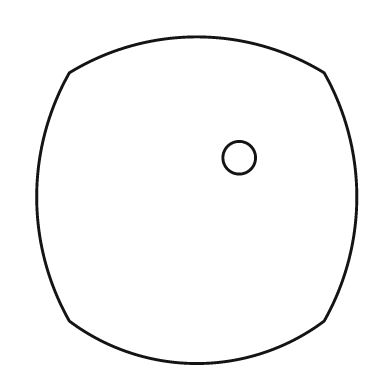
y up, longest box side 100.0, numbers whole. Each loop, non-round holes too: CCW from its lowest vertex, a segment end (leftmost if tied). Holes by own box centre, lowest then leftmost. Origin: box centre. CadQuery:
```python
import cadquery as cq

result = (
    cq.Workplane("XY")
    .moveTo(-39.0, -37.0)
    .threePointArc((0.0, -50.0), (39.0, -37.0))
    .threePointArc((49.0, 1.0), (39.0, 39.0))
    .threePointArc((0.0, 50.0), (-39.0, 39.0))
    .threePointArc((-49.0, 1.0), (-39.0, -37.0))
    .close()
    .moveTo(13.0, 13.0)
    .circle(5.0)
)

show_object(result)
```